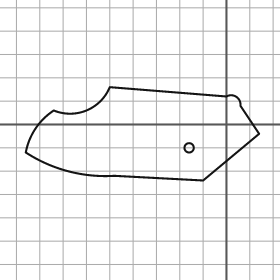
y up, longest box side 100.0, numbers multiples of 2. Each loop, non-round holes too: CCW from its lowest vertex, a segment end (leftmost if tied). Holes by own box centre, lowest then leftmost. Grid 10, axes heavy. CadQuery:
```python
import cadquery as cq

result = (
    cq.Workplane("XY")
    .moveTo(-10.0, -24.0)
    .lineTo(14.0, -4.0)
    .lineTo(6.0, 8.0)
    .threePointArc((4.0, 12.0), (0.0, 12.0))
    .lineTo(-50.0, 16.0)
    .threePointArc((-60.0, 6.0), (-74.0, 6.0))
    .threePointArc((-82.0, -2.0), (-86.0, -12.0))
    .threePointArc((-68.0, -20.0), (-48.0, -22.0))
    .close()
    .moveTo(-16.0, -10.0)
    .circle(2.0)
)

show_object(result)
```